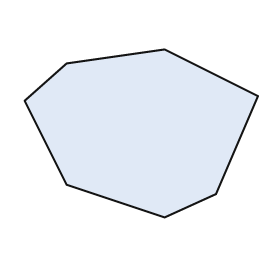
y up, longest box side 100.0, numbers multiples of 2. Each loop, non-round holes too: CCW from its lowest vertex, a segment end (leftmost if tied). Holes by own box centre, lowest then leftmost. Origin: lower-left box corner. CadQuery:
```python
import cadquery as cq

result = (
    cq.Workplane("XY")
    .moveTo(60.0, 0.0)
    .lineTo(82.0, 10.0)
    .lineTo(100.0, 52.0)
    .lineTo(60.0, 72.0)
    .lineTo(18.0, 66.0)
    .lineTo(0.0, 50.0)
    .lineTo(18.0, 14.0)
    .close()
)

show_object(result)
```